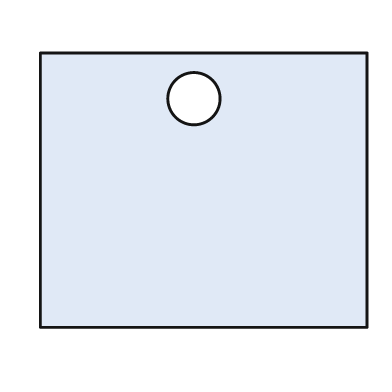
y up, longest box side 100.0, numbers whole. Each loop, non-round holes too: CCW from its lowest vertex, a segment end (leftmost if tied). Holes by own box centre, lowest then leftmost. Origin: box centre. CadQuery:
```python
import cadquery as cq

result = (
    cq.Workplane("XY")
    .moveTo(-50.0, -42.0)
    .lineTo(50.0, -42.0)
    .lineTo(50.0, 42.0)
    .lineTo(-50.0, 42.0)
    .close()
    .moveTo(-3.0, 28.0)
    .circle(8.0)
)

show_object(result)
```